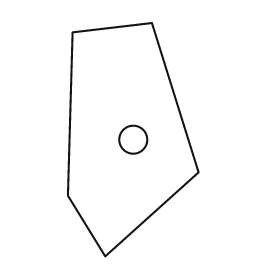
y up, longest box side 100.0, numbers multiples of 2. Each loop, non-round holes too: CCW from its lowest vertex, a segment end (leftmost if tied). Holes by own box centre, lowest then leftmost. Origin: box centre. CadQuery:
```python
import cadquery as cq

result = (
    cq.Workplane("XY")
    .moveTo(-12.0, -50.0)
    .lineTo(28.0, -14.0)
    .lineTo(8.0, 50.0)
    .lineTo(-26.0, 46.0)
    .lineTo(-28.0, -24.0)
    .close()
    .moveTo(0.0, 0.0)
    .circle(6.0)
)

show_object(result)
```